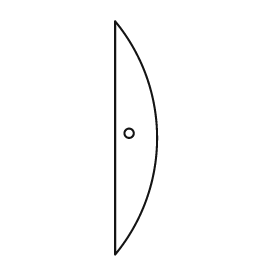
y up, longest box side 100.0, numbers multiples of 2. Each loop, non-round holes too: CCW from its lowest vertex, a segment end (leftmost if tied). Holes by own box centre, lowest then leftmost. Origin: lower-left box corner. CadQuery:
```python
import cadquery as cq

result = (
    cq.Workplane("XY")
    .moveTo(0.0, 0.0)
    .threePointArc((18.0, 50.0), (0.0, 100.0))
    .close()
    .moveTo(6.0, 52.0)
    .circle(2.0)
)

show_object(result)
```